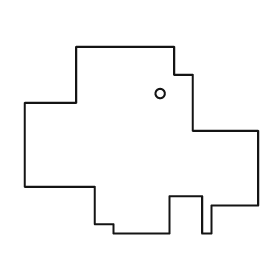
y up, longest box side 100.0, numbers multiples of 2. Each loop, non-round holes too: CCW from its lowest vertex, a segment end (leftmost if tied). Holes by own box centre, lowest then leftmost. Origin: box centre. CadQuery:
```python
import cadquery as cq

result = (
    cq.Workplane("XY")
    .moveTo(-12.0, -40.0)
    .lineTo(12.0, -40.0)
    .lineTo(12.0, -24.0)
    .lineTo(26.0, -24.0)
    .lineTo(26.0, -40.0)
    .lineTo(30.0, -40.0)
    .lineTo(30.0, -28.0)
    .lineTo(50.0, -28.0)
    .lineTo(50.0, 4.0)
    .lineTo(22.0, 4.0)
    .lineTo(22.0, 28.0)
    .lineTo(14.0, 28.0)
    .lineTo(14.0, 40.0)
    .lineTo(-28.0, 40.0)
    .lineTo(-28.0, 16.0)
    .lineTo(-50.0, 16.0)
    .lineTo(-50.0, -20.0)
    .lineTo(-20.0, -20.0)
    .lineTo(-20.0, -36.0)
    .lineTo(-12.0, -36.0)
    .close()
    .moveTo(8.0, 20.0)
    .circle(2.0)
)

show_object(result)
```